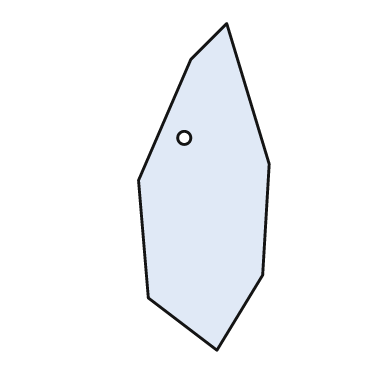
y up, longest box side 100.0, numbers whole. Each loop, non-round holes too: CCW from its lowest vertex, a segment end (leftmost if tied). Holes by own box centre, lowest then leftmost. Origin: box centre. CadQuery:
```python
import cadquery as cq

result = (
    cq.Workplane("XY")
    .moveTo(4.0, -50.0)
    .lineTo(18.0, -27.0)
    .lineTo(20.0, 7.0)
    .lineTo(7.0, 50.0)
    .lineTo(-4.0, 39.0)
    .lineTo(-20.0, 2.0)
    .lineTo(-17.0, -34.0)
    .close()
    .moveTo(-6.0, 15.0)
    .circle(2.0)
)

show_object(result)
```